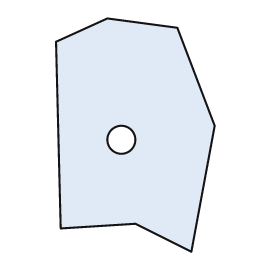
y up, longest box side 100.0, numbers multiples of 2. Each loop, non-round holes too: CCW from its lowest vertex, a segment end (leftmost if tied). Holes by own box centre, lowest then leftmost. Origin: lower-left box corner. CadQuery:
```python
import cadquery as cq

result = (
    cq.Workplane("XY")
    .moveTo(58.0, 0.0)
    .lineTo(68.0, 54.0)
    .lineTo(52.0, 96.0)
    .lineTo(22.0, 100.0)
    .lineTo(0.0, 90.0)
    .lineTo(2.0, 10.0)
    .lineTo(34.0, 12.0)
    .close()
    .moveTo(28.0, 48.0)
    .circle(6.0)
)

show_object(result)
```